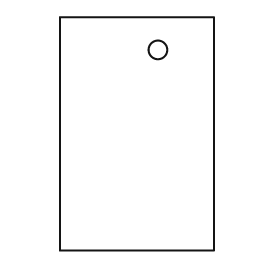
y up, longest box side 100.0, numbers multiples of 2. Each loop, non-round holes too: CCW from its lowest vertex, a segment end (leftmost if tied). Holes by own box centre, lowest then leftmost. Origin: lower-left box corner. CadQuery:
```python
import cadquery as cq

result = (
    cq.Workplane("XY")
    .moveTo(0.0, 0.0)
    .lineTo(66.0, 0.0)
    .lineTo(66.0, 100.0)
    .lineTo(0.0, 100.0)
    .close()
    .moveTo(42.0, 86.0)
    .circle(4.0)
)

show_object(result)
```